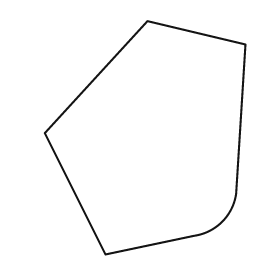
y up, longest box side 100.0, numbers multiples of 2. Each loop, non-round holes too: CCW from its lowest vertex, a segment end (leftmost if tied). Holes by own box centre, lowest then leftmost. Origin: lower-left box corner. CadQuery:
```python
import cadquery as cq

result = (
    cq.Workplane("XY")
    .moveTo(26.0, 0.0)
    .lineTo(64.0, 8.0)
    .threePointArc((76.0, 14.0), (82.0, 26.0))
    .lineTo(86.0, 90.0)
    .lineTo(44.0, 100.0)
    .lineTo(0.0, 52.0)
    .close()
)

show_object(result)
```